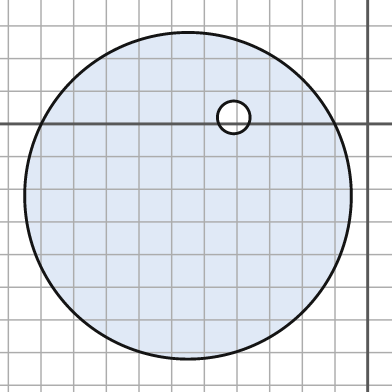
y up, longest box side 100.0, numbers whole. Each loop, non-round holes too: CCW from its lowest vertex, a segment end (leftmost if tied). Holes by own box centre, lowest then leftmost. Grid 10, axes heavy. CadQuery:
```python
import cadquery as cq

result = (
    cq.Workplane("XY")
    .moveTo(-55.0, -22.0)
    .circle(50.0)
    .moveTo(-41.0, 2.0)
    .circle(5.0)
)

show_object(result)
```